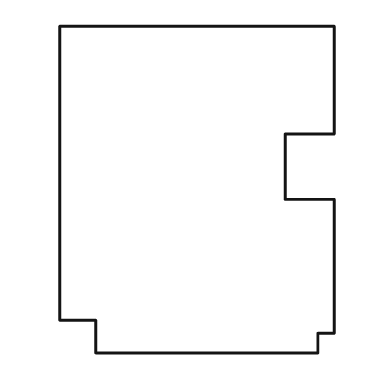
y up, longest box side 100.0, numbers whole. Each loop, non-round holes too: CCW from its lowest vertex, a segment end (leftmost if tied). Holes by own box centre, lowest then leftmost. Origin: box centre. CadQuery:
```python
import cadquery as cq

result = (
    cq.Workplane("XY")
    .moveTo(-31.0, -50.0)
    .lineTo(37.0, -50.0)
    .lineTo(37.0, -44.0)
    .lineTo(42.0, -44.0)
    .lineTo(42.0, -3.0)
    .lineTo(27.0, -3.0)
    .lineTo(27.0, 17.0)
    .lineTo(42.0, 17.0)
    .lineTo(42.0, 50.0)
    .lineTo(-42.0, 50.0)
    .lineTo(-42.0, -40.0)
    .lineTo(-31.0, -40.0)
    .close()
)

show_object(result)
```